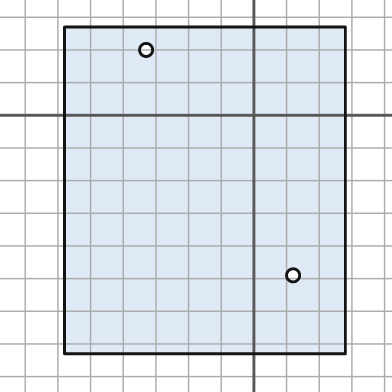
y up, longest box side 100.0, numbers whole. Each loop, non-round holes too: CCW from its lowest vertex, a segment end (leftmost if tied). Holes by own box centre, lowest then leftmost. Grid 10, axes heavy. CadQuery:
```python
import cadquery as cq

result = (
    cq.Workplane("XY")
    .moveTo(-58.0, -73.0)
    .lineTo(28.0, -73.0)
    .lineTo(28.0, 27.0)
    .lineTo(-58.0, 27.0)
    .close()
    .moveTo(12.0, -49.0)
    .circle(2.0)
    .moveTo(-33.0, 20.0)
    .circle(2.0)
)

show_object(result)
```